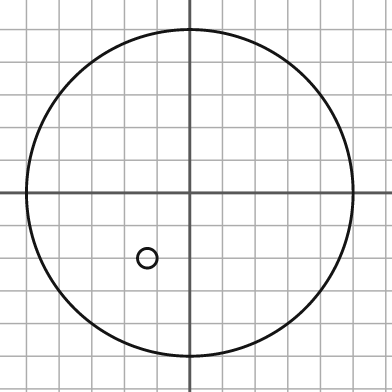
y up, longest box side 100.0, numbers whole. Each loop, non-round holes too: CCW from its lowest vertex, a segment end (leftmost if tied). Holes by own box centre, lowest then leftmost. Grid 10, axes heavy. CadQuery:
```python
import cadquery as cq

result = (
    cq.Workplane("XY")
    .moveTo(0.0, 0.0)
    .circle(50.0)
    .moveTo(-13.0, -20.0)
    .circle(3.0)
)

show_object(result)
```